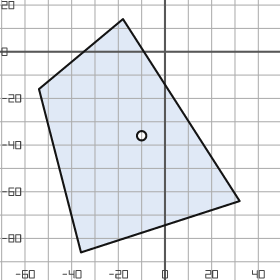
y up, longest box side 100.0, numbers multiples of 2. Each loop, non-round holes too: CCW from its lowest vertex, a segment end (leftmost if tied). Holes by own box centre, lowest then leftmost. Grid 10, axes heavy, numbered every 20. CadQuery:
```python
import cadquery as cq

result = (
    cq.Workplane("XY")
    .moveTo(-36.0, -86.0)
    .lineTo(32.0, -64.0)
    .lineTo(-18.0, 14.0)
    .lineTo(-54.0, -16.0)
    .close()
    .moveTo(-10.0, -36.0)
    .circle(2.0)
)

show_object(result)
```